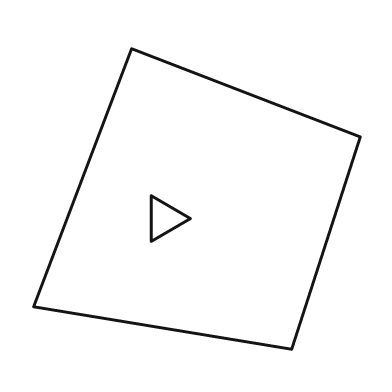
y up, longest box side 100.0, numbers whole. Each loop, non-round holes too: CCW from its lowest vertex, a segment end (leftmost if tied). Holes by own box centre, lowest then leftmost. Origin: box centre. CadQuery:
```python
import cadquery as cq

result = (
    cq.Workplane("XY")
    .moveTo(29.0, -46.0)
    .lineTo(50.0, 19.0)
    .lineTo(-20.0, 46.0)
    .lineTo(-50.0, -33.0)
    .close()
    .moveTo(-14.0, -13.0)
    .lineTo(-2.0, -6.0)
    .lineTo(-14.0, 1.0)
    .close()
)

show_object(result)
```